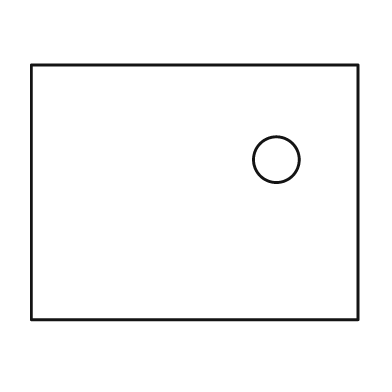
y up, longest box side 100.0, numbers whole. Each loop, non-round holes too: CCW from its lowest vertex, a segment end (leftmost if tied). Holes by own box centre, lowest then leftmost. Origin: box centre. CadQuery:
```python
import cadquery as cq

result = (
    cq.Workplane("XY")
    .moveTo(-50.0, -39.0)
    .lineTo(50.0, -39.0)
    .lineTo(50.0, 39.0)
    .lineTo(-50.0, 39.0)
    .close()
    .moveTo(25.0, 10.0)
    .circle(7.0)
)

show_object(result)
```